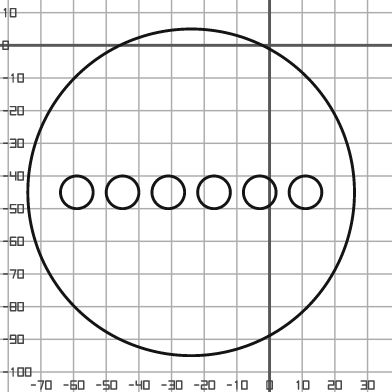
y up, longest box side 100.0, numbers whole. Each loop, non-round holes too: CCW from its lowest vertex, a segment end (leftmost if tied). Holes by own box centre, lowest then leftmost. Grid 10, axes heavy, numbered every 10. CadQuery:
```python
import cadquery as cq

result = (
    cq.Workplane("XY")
    .moveTo(-24.0, -45.0)
    .circle(50.0)
    .moveTo(-59.0, -45.0)
    .circle(5.0)
    .moveTo(-45.0, -45.0)
    .circle(5.0)
    .moveTo(-31.0, -45.0)
    .circle(5.0)
    .moveTo(-17.0, -45.0)
    .circle(5.0)
    .moveTo(-3.0, -45.0)
    .circle(5.0)
    .moveTo(11.0, -45.0)
    .circle(5.0)
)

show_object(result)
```